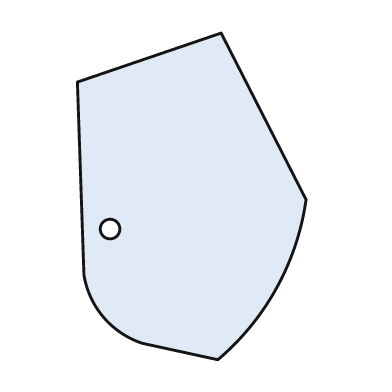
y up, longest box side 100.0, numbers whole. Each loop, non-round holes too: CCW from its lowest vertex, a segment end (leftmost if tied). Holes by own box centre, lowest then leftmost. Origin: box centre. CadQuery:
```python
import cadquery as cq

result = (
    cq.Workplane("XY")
    .moveTo(8.0, -50.0)
    .threePointArc((26.0, -28.0), (35.0, -1.0))
    .lineTo(9.0, 50.0)
    .lineTo(-35.0, 35.0)
    .lineTo(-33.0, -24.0)
    .threePointArc((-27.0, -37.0), (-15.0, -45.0))
    .close()
    .moveTo(-25.0, -10.0)
    .circle(3.0)
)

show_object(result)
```